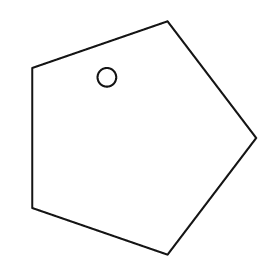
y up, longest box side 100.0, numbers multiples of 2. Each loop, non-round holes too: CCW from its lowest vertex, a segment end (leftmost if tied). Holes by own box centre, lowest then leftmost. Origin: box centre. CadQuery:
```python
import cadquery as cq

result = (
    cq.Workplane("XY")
    .moveTo(10.0, -50.0)
    .lineTo(48.0, 0.0)
    .lineTo(10.0, 50.0)
    .lineTo(-48.0, 30.0)
    .lineTo(-48.0, -30.0)
    .close()
    .moveTo(-16.0, 26.0)
    .circle(4.0)
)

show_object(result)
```